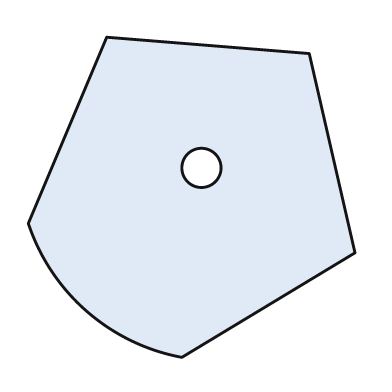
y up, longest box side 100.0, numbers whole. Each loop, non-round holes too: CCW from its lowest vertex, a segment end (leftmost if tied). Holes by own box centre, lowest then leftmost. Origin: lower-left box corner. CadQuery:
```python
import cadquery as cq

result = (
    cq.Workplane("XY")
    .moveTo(47.0, 0.0)
    .lineTo(100.0, 32.0)
    .lineTo(86.0, 93.0)
    .lineTo(24.0, 98.0)
    .lineTo(0.0, 41.0)
    .threePointArc((18.0, 14.0), (47.0, 0.0))
    .close()
    .moveTo(53.0, 58.0)
    .circle(6.0)
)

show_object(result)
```